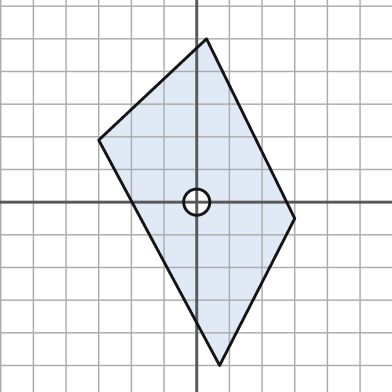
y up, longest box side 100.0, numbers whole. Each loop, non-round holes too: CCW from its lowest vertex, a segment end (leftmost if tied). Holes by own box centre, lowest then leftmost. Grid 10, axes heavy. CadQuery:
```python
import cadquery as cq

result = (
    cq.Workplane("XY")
    .moveTo(7.0, -50.0)
    .lineTo(30.0, -5.0)
    .lineTo(3.0, 50.0)
    .lineTo(-30.0, 19.0)
    .close()
    .moveTo(0.0, 0.0)
    .circle(4.0)
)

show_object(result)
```